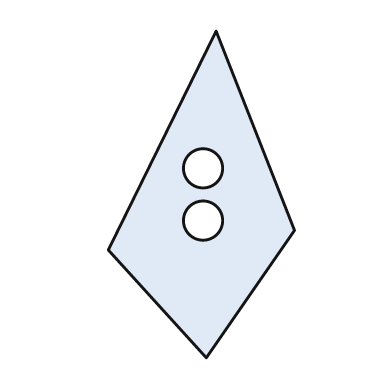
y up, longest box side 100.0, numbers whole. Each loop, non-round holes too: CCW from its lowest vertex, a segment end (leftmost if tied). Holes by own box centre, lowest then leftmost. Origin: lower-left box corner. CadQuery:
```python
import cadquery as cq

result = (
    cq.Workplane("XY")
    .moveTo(30.0, 0.0)
    .lineTo(57.0, 39.0)
    .lineTo(33.0, 100.0)
    .lineTo(0.0, 33.0)
    .close()
    .moveTo(29.0, 42.0)
    .circle(6.0)
    .moveTo(29.0, 58.0)
    .circle(6.0)
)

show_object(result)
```